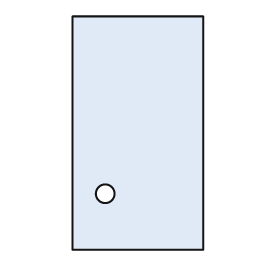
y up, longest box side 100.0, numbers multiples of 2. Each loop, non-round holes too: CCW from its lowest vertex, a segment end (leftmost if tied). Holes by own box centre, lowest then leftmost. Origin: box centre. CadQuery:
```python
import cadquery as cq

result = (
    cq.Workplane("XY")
    .moveTo(-28.0, -50.0)
    .lineTo(28.0, -50.0)
    .lineTo(28.0, 50.0)
    .lineTo(-28.0, 50.0)
    .close()
    .moveTo(-14.0, -26.0)
    .circle(4.0)
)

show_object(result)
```